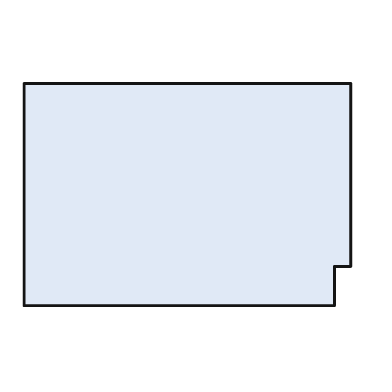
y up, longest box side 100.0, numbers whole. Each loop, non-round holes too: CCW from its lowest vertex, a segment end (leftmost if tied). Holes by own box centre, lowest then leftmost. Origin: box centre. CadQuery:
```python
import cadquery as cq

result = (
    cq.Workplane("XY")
    .moveTo(-50.0, -34.0)
    .lineTo(45.0, -34.0)
    .lineTo(45.0, -22.0)
    .lineTo(50.0, -22.0)
    .lineTo(50.0, 34.0)
    .lineTo(-50.0, 34.0)
    .close()
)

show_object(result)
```